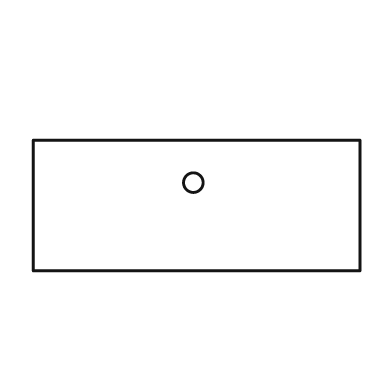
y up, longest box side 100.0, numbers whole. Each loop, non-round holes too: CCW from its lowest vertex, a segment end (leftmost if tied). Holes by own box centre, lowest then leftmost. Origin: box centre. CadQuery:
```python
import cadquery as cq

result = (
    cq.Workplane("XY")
    .moveTo(-50.0, -20.0)
    .lineTo(50.0, -20.0)
    .lineTo(50.0, 20.0)
    .lineTo(-50.0, 20.0)
    .close()
    .moveTo(-1.0, 7.0)
    .circle(3.0)
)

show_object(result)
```